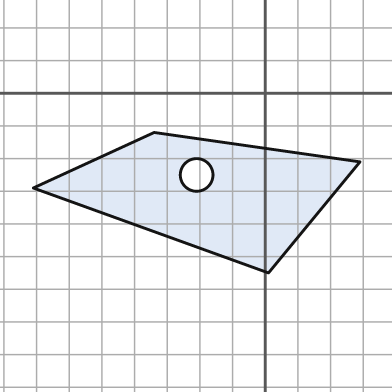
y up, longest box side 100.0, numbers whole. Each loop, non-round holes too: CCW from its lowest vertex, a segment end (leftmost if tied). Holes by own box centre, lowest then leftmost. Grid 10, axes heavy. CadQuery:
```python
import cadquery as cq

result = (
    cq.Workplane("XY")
    .moveTo(1.0, -55.0)
    .lineTo(29.0, -21.0)
    .lineTo(-34.0, -12.0)
    .lineTo(-71.0, -29.0)
    .close()
    .moveTo(-21.0, -25.0)
    .circle(5.0)
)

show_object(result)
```